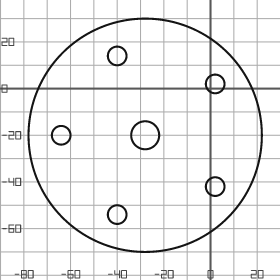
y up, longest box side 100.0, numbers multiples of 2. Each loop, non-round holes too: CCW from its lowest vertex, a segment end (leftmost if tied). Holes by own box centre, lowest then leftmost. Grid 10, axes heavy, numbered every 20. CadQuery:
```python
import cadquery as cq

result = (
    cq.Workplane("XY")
    .moveTo(-28.0, -20.0)
    .circle(50.0)
    .moveTo(-40.0, -54.0)
    .circle(4.0)
    .moveTo(2.0, -42.0)
    .circle(4.0)
    .moveTo(-64.0, -20.0)
    .circle(4.0)
    .moveTo(-28.0, -20.0)
    .circle(6.0)
    .moveTo(2.0, 2.0)
    .circle(4.0)
    .moveTo(-40.0, 14.0)
    .circle(4.0)
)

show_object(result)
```